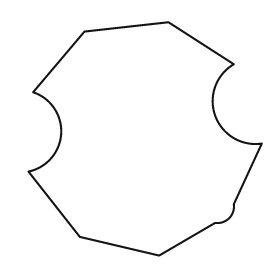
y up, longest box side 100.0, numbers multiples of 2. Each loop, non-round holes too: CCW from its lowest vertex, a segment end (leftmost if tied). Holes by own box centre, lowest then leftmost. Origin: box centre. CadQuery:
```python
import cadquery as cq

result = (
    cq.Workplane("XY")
    .moveTo(6.0, -50.0)
    .lineTo(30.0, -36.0)
    .threePointArc((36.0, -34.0), (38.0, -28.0))
    .lineTo(50.0, -2.0)
    .threePointArc((30.0, 10.0), (38.0, 32.0))
    .lineTo(10.0, 50.0)
    .lineTo(-26.0, 46.0)
    .lineTo(-48.0, 20.0)
    .threePointArc((-36.0, 2.0), (-50.0, -14.0))
    .lineTo(-28.0, -42.0)
    .close()
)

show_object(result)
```